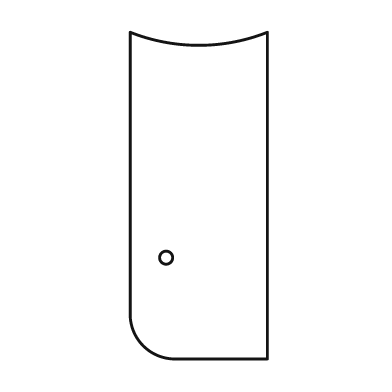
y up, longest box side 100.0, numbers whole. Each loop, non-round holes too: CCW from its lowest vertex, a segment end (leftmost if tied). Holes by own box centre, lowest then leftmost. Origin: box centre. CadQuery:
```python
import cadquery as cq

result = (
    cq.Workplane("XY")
    .moveTo(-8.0, -50.0)
    .lineTo(21.0, -50.0)
    .lineTo(21.0, 50.0)
    .threePointArc((0.0, 46.0), (-21.0, 50.0))
    .lineTo(-21.0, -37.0)
    .threePointArc((-17.0, -46.0), (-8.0, -50.0))
    .close()
    .moveTo(-10.0, -19.0)
    .circle(2.0)
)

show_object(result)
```